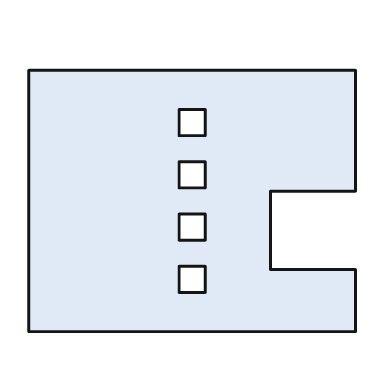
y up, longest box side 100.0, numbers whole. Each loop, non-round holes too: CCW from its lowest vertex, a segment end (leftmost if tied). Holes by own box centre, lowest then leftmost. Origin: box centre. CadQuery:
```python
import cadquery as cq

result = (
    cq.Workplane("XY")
    .moveTo(-50.0, -40.0)
    .lineTo(50.0, -40.0)
    .lineTo(50.0, -21.0)
    .lineTo(24.0, -21.0)
    .lineTo(24.0, 3.0)
    .lineTo(50.0, 3.0)
    .lineTo(50.0, 40.0)
    .lineTo(-50.0, 40.0)
    .close()
    .moveTo(-4.0, -28.0)
    .lineTo(4.0, -28.0)
    .lineTo(4.0, -20.0)
    .lineTo(-4.0, -20.0)
    .close()
    .moveTo(-4.0, -12.0)
    .lineTo(4.0, -12.0)
    .lineTo(4.0, -4.0)
    .lineTo(-4.0, -4.0)
    .close()
    .moveTo(-4.0, 4.0)
    .lineTo(4.0, 4.0)
    .lineTo(4.0, 12.0)
    .lineTo(-4.0, 12.0)
    .close()
    .moveTo(-4.0, 20.0)
    .lineTo(4.0, 20.0)
    .lineTo(4.0, 28.0)
    .lineTo(-4.0, 28.0)
    .close()
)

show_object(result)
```